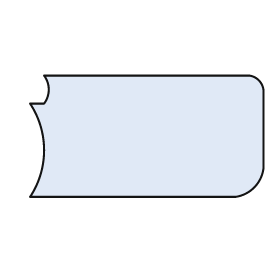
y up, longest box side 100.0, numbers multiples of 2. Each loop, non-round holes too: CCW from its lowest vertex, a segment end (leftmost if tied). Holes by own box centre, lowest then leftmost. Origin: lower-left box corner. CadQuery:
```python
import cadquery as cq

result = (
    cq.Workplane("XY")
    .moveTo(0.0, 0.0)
    .lineTo(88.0, 0.0)
    .threePointArc((96.0, 4.0), (100.0, 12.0))
    .lineTo(100.0, 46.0)
    .threePointArc((98.0, 50.0), (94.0, 52.0))
    .lineTo(6.0, 52.0)
    .threePointArc((8.0, 46.0), (6.0, 40.0))
    .lineTo(0.0, 40.0)
    .threePointArc((6.0, 20.0), (0.0, 0.0))
    .close()
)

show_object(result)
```